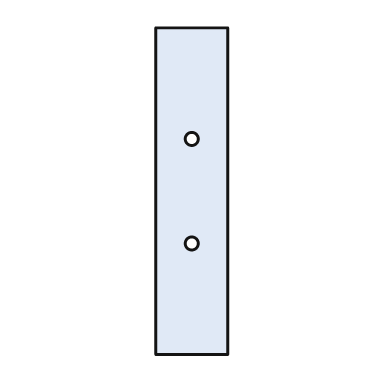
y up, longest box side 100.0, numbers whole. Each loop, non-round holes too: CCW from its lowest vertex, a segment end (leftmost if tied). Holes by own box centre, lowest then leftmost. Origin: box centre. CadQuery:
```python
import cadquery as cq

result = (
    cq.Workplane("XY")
    .moveTo(-11.0, -50.0)
    .lineTo(11.0, -50.0)
    .lineTo(11.0, 50.0)
    .lineTo(-11.0, 50.0)
    .close()
    .moveTo(0.0, -16.0)
    .circle(2.0)
    .moveTo(0.0, 16.0)
    .circle(2.0)
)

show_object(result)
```